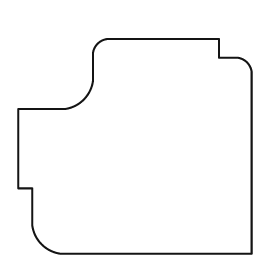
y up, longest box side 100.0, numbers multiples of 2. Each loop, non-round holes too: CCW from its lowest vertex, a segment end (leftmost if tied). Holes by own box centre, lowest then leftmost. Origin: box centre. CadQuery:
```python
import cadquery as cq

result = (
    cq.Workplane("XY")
    .moveTo(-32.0, -46.0)
    .lineTo(50.0, -46.0)
    .lineTo(50.0, 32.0)
    .threePointArc((48.0, 36.0), (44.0, 38.0))
    .lineTo(36.0, 38.0)
    .lineTo(36.0, 46.0)
    .lineTo(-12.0, 46.0)
    .threePointArc((-16.0, 44.0), (-18.0, 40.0))
    .lineTo(-18.0, 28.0)
    .threePointArc((-22.0, 20.0), (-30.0, 16.0))
    .lineTo(-50.0, 16.0)
    .lineTo(-50.0, -18.0)
    .lineTo(-44.0, -18.0)
    .lineTo(-44.0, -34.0)
    .threePointArc((-40.0, -42.0), (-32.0, -46.0))
    .close()
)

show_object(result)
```